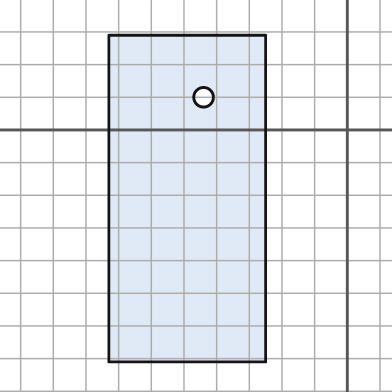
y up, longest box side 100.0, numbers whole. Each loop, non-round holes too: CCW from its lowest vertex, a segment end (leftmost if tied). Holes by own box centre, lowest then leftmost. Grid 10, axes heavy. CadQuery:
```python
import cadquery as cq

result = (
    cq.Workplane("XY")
    .moveTo(-73.0, -71.0)
    .lineTo(-25.0, -71.0)
    .lineTo(-25.0, 29.0)
    .lineTo(-73.0, 29.0)
    .close()
    .moveTo(-44.0, 10.0)
    .circle(3.0)
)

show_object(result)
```